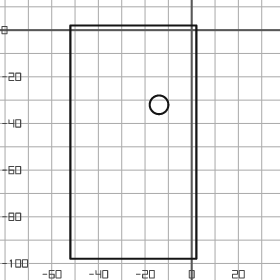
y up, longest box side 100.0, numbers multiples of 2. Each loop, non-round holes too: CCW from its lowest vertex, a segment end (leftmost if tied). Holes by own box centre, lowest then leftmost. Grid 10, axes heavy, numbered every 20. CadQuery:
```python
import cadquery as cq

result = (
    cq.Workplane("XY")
    .moveTo(-52.0, -98.0)
    .lineTo(2.0, -98.0)
    .lineTo(2.0, 2.0)
    .lineTo(-52.0, 2.0)
    .close()
    .moveTo(-14.0, -32.0)
    .circle(4.0)
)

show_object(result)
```